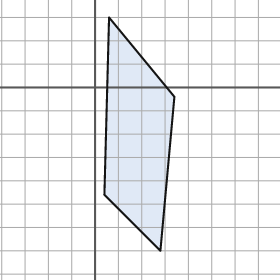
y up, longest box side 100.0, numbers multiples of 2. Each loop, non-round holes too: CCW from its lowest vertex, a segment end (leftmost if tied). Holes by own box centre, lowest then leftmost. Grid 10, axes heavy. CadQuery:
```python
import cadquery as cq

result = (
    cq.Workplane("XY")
    .moveTo(28.0, -70.0)
    .lineTo(34.0, -4.0)
    .lineTo(6.0, 30.0)
    .lineTo(4.0, -46.0)
    .close()
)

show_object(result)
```